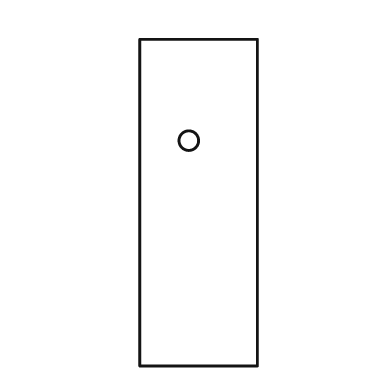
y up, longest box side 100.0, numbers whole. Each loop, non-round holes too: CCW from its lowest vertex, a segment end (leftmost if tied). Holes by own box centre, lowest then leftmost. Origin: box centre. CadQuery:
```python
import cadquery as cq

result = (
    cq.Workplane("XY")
    .moveTo(-18.0, -50.0)
    .lineTo(18.0, -50.0)
    .lineTo(18.0, 50.0)
    .lineTo(-18.0, 50.0)
    .close()
    .moveTo(-3.0, 19.0)
    .circle(3.0)
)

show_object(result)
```